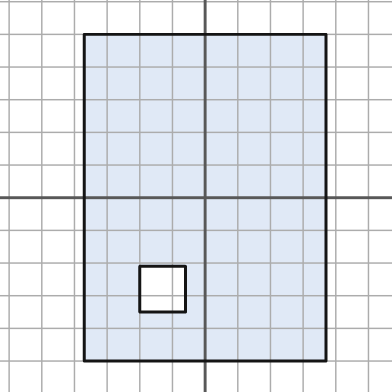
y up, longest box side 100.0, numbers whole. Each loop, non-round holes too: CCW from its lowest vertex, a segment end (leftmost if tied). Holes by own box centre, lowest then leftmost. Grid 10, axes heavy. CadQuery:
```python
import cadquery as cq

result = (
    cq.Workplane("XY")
    .moveTo(-37.0, -50.0)
    .lineTo(37.0, -50.0)
    .lineTo(37.0, 50.0)
    .lineTo(-37.0, 50.0)
    .close()
    .moveTo(-20.0, -35.0)
    .lineTo(-6.0, -35.0)
    .lineTo(-6.0, -21.0)
    .lineTo(-20.0, -21.0)
    .close()
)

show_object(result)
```